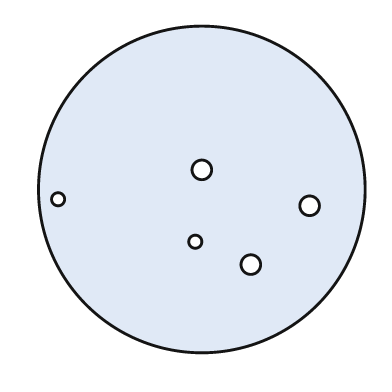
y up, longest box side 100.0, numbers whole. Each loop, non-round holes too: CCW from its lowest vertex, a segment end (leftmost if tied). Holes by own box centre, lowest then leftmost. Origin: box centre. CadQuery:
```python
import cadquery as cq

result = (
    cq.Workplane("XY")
    .moveTo(0.0, 0.0)
    .circle(50.0)
    .moveTo(15.0, -23.0)
    .circle(3.0)
    .moveTo(-2.0, -16.0)
    .circle(2.0)
    .moveTo(33.0, -5.0)
    .circle(3.0)
    .moveTo(-44.0, -3.0)
    .circle(2.0)
    .moveTo(0.0, 6.0)
    .circle(3.0)
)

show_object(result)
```